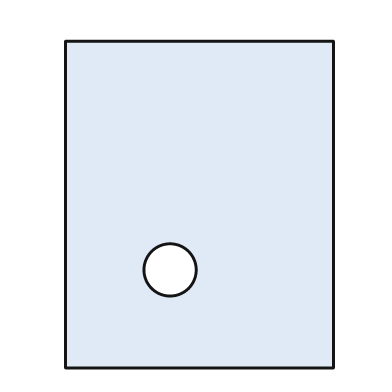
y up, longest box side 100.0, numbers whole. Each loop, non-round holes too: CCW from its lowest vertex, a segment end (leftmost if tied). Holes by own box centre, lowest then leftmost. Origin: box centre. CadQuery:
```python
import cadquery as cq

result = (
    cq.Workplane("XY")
    .moveTo(-41.0, -50.0)
    .lineTo(41.0, -50.0)
    .lineTo(41.0, 50.0)
    .lineTo(-41.0, 50.0)
    .close()
    .moveTo(-9.0, -20.0)
    .circle(8.0)
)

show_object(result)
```